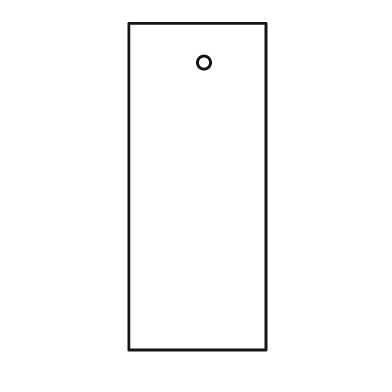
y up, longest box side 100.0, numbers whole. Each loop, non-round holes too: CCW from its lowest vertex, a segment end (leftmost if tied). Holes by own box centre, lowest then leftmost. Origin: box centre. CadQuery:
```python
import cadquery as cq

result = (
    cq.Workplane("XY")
    .moveTo(-21.0, -50.0)
    .lineTo(21.0, -50.0)
    .lineTo(21.0, 50.0)
    .lineTo(-21.0, 50.0)
    .close()
    .moveTo(2.0, 38.0)
    .circle(2.0)
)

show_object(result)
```